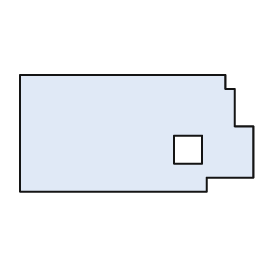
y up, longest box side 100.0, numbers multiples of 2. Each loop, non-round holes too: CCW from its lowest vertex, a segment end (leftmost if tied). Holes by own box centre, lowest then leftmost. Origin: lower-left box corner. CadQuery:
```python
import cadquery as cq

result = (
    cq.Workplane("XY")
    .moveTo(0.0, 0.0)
    .lineTo(80.0, 0.0)
    .lineTo(80.0, 6.0)
    .lineTo(100.0, 6.0)
    .lineTo(100.0, 28.0)
    .lineTo(92.0, 28.0)
    .lineTo(92.0, 44.0)
    .lineTo(88.0, 44.0)
    .lineTo(88.0, 50.0)
    .lineTo(0.0, 50.0)
    .close()
    .moveTo(66.0, 12.0)
    .lineTo(78.0, 12.0)
    .lineTo(78.0, 24.0)
    .lineTo(66.0, 24.0)
    .close()
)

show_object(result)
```